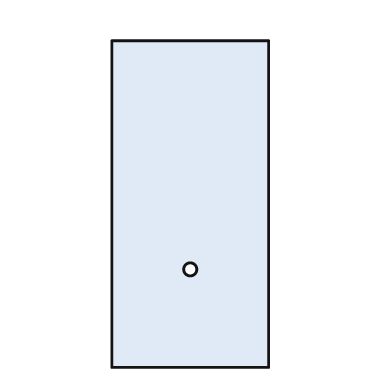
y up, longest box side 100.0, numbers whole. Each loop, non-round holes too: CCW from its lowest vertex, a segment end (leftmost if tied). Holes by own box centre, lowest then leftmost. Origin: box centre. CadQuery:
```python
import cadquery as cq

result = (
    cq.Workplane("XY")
    .moveTo(-24.0, -50.0)
    .lineTo(24.0, -50.0)
    .lineTo(24.0, 50.0)
    .lineTo(-24.0, 50.0)
    .close()
    .moveTo(0.0, -20.0)
    .circle(2.0)
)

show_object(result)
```